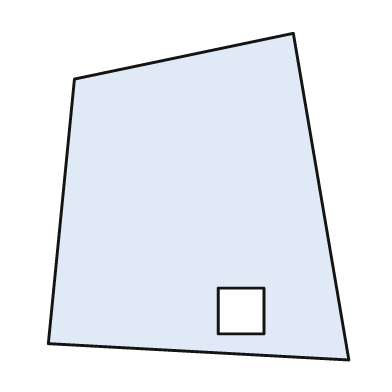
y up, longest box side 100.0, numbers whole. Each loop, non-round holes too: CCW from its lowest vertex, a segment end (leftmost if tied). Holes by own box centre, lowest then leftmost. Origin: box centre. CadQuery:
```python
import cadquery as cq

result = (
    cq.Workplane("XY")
    .moveTo(46.0, -50.0)
    .lineTo(29.0, 50.0)
    .lineTo(-38.0, 36.0)
    .lineTo(-46.0, -45.0)
    .close()
    .moveTo(6.0, -42.0)
    .lineTo(20.0, -42.0)
    .lineTo(20.0, -28.0)
    .lineTo(6.0, -28.0)
    .close()
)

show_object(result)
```